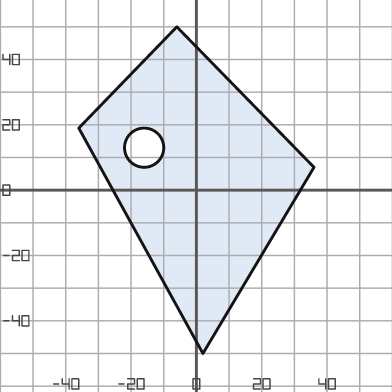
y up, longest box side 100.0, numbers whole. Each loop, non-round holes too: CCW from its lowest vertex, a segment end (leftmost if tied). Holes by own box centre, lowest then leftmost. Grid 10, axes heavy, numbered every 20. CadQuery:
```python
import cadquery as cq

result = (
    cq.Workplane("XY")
    .moveTo(2.0, -50.0)
    .lineTo(36.0, 7.0)
    .lineTo(-6.0, 50.0)
    .lineTo(-36.0, 19.0)
    .close()
    .moveTo(-16.0, 13.0)
    .circle(6.0)
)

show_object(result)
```